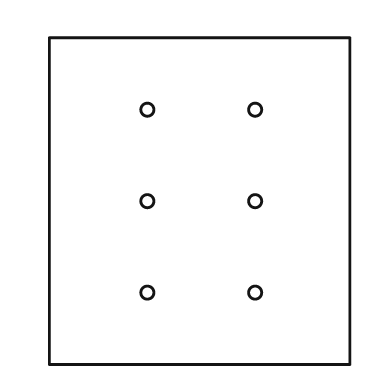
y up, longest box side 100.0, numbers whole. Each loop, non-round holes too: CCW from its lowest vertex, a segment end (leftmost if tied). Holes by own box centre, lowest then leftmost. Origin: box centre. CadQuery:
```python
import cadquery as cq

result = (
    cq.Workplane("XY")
    .moveTo(-46.0, -50.0)
    .lineTo(46.0, -50.0)
    .lineTo(46.0, 50.0)
    .lineTo(-46.0, 50.0)
    .close()
    .moveTo(-16.0, -28.0)
    .circle(2.0)
    .moveTo(17.0, -28.0)
    .circle(2.0)
    .moveTo(-16.0, 0.0)
    .circle(2.0)
    .moveTo(17.0, 0.0)
    .circle(2.0)
    .moveTo(-16.0, 28.0)
    .circle(2.0)
    .moveTo(17.0, 28.0)
    .circle(2.0)
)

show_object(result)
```